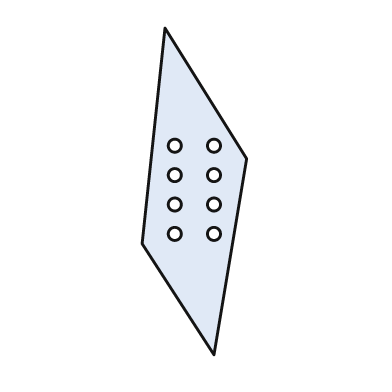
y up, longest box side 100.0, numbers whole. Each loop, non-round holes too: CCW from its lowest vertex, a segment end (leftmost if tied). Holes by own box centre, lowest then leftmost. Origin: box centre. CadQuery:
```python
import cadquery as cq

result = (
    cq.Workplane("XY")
    .moveTo(6.0, -50.0)
    .lineTo(16.0, 10.0)
    .lineTo(-9.0, 50.0)
    .lineTo(-16.0, -16.0)
    .close()
    .moveTo(-6.0, -13.0)
    .circle(2.0)
    .moveTo(6.0, -13.0)
    .circle(2.0)
    .moveTo(-6.0, -4.0)
    .circle(2.0)
    .moveTo(6.0, -4.0)
    .circle(2.0)
    .moveTo(-6.0, 5.0)
    .circle(2.0)
    .moveTo(6.0, 5.0)
    .circle(2.0)
    .moveTo(-6.0, 14.0)
    .circle(2.0)
    .moveTo(6.0, 14.0)
    .circle(2.0)
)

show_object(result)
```